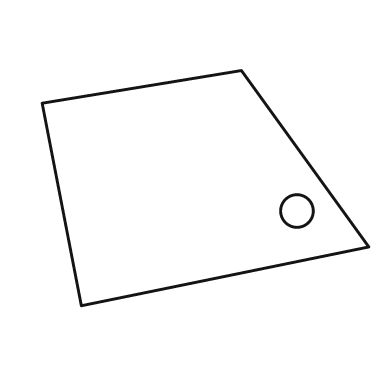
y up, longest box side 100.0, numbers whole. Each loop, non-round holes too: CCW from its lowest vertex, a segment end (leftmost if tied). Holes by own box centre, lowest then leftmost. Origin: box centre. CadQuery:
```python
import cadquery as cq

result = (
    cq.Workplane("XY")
    .moveTo(-38.0, -36.0)
    .lineTo(50.0, -18.0)
    .lineTo(11.0, 36.0)
    .lineTo(-50.0, 26.0)
    .close()
    .moveTo(28.0, -7.0)
    .circle(5.0)
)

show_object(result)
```